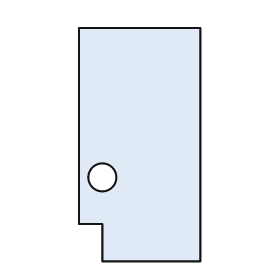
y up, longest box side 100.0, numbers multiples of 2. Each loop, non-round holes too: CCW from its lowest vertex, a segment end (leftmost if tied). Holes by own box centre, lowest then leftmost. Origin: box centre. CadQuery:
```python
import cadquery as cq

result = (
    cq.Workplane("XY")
    .moveTo(-16.0, -50.0)
    .lineTo(26.0, -50.0)
    .lineTo(26.0, 50.0)
    .lineTo(-26.0, 50.0)
    .lineTo(-26.0, -34.0)
    .lineTo(-16.0, -34.0)
    .close()
    .moveTo(-16.0, -14.0)
    .circle(6.0)
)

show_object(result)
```